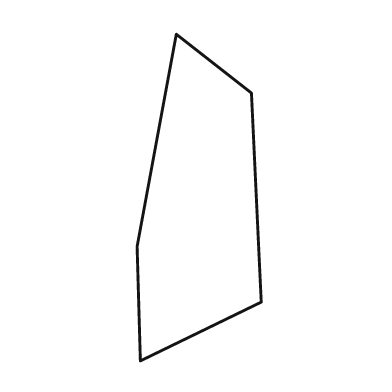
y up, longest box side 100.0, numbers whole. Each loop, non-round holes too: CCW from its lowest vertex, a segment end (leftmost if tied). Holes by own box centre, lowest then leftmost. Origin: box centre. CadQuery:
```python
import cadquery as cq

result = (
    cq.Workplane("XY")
    .moveTo(-18.0, -50.0)
    .lineTo(19.0, -32.0)
    .lineTo(16.0, 32.0)
    .lineTo(-7.0, 50.0)
    .lineTo(-19.0, -15.0)
    .close()
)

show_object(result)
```